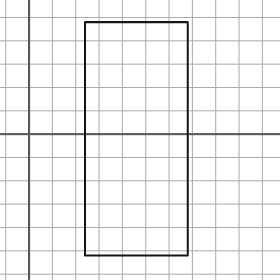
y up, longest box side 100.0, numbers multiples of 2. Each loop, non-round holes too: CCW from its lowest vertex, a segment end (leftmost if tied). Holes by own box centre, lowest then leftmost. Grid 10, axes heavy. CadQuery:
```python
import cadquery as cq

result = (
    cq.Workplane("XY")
    .moveTo(24.0, -52.0)
    .lineTo(68.0, -52.0)
    .lineTo(68.0, 48.0)
    .lineTo(24.0, 48.0)
    .close()
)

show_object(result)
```